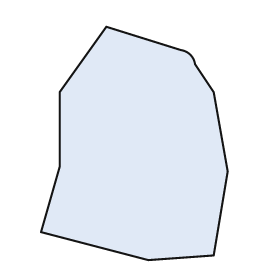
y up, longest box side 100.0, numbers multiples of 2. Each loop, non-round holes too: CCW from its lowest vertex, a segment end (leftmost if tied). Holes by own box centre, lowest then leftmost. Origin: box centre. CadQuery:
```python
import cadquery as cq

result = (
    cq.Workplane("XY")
    .moveTo(6.0, -50.0)
    .lineTo(34.0, -48.0)
    .lineTo(40.0, -12.0)
    .lineTo(34.0, 22.0)
    .lineTo(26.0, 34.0)
    .threePointArc((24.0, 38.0), (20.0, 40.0))
    .lineTo(-12.0, 50.0)
    .lineTo(-32.0, 22.0)
    .lineTo(-32.0, -10.0)
    .lineTo(-40.0, -38.0)
    .close()
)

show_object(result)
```